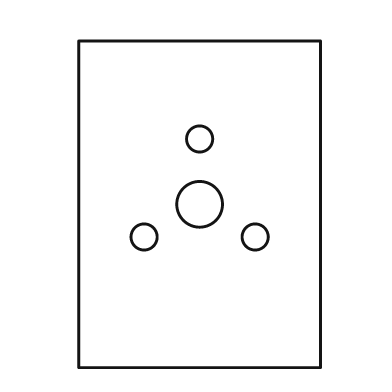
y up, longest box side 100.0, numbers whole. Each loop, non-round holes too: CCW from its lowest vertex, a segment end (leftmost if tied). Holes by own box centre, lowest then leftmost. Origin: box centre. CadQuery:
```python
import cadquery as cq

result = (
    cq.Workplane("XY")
    .moveTo(-37.0, -50.0)
    .lineTo(37.0, -50.0)
    .lineTo(37.0, 50.0)
    .lineTo(-37.0, 50.0)
    .close()
    .moveTo(-17.0, -10.0)
    .circle(4.0)
    .moveTo(17.0, -10.0)
    .circle(4.0)
    .moveTo(0.0, 0.0)
    .circle(7.0)
    .moveTo(0.0, 20.0)
    .circle(4.0)
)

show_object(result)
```